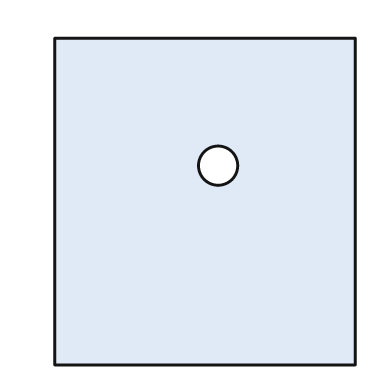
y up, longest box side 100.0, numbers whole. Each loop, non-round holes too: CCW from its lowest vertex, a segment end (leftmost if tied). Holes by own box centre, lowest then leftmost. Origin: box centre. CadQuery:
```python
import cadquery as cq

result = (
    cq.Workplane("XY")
    .moveTo(-46.0, -50.0)
    .lineTo(46.0, -50.0)
    .lineTo(46.0, 50.0)
    .lineTo(-46.0, 50.0)
    .close()
    .moveTo(4.0, 11.0)
    .circle(6.0)
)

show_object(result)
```